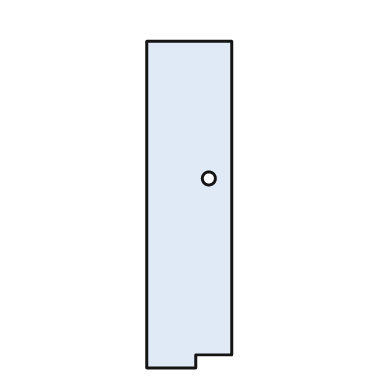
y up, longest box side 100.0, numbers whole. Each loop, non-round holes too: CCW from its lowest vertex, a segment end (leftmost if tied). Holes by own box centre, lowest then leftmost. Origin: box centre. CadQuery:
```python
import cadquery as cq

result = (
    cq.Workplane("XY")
    .moveTo(-13.0, -50.0)
    .lineTo(2.0, -50.0)
    .lineTo(2.0, -46.0)
    .lineTo(13.0, -46.0)
    .lineTo(13.0, 50.0)
    .lineTo(-13.0, 50.0)
    .close()
    .moveTo(6.0, 8.0)
    .circle(2.0)
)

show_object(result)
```